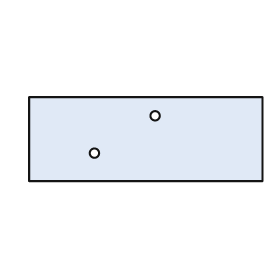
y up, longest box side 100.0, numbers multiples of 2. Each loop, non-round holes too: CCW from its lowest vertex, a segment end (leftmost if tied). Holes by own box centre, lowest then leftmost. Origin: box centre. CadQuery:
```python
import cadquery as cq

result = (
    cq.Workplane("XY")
    .moveTo(-50.0, -18.0)
    .lineTo(50.0, -18.0)
    .lineTo(50.0, 18.0)
    .lineTo(-50.0, 18.0)
    .close()
    .moveTo(-22.0, -6.0)
    .circle(2.0)
    .moveTo(4.0, 10.0)
    .circle(2.0)
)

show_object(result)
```